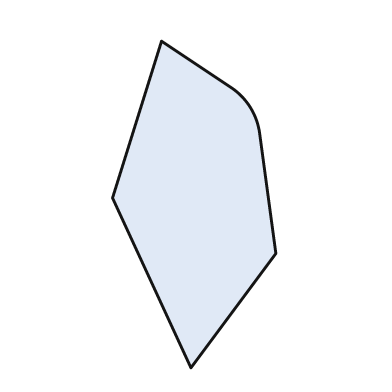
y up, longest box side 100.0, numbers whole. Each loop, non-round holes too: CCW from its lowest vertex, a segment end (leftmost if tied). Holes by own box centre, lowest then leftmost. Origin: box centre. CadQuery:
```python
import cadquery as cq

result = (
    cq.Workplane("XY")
    .moveTo(-1.0, -50.0)
    .lineTo(25.0, -15.0)
    .lineTo(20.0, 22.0)
    .threePointArc((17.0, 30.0), (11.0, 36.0))
    .lineTo(-10.0, 50.0)
    .lineTo(-25.0, 2.0)
    .close()
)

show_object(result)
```